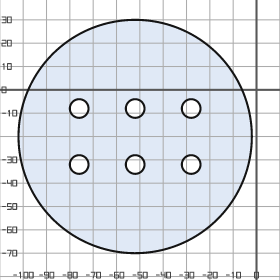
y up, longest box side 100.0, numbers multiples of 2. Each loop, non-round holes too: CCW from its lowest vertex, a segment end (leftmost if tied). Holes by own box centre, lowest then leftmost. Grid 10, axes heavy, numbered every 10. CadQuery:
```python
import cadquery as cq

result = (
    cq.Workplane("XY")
    .moveTo(-52.0, -20.0)
    .circle(50.0)
    .moveTo(-76.0, -32.0)
    .circle(4.0)
    .moveTo(-52.0, -32.0)
    .circle(4.0)
    .moveTo(-28.0, -32.0)
    .circle(4.0)
    .moveTo(-76.0, -8.0)
    .circle(4.0)
    .moveTo(-52.0, -8.0)
    .circle(4.0)
    .moveTo(-28.0, -8.0)
    .circle(4.0)
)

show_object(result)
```